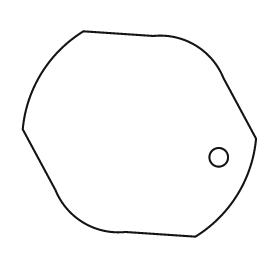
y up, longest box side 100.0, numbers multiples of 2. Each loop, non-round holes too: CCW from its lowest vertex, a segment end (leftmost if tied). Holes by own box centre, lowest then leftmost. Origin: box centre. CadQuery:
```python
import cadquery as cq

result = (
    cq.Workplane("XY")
    .moveTo(24.0, -44.0)
    .threePointArc((42.0, -26.0), (50.0, -2.0))
    .lineTo(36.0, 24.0)
    .threePointArc((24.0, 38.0), (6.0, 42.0))
    .lineTo(-24.0, 44.0)
    .threePointArc((-42.0, 26.0), (-50.0, 2.0))
    .lineTo(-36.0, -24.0)
    .threePointArc((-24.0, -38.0), (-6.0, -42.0))
    .close()
    .moveTo(34.0, -10.0)
    .circle(4.0)
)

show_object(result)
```